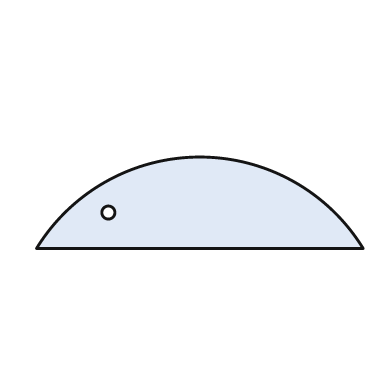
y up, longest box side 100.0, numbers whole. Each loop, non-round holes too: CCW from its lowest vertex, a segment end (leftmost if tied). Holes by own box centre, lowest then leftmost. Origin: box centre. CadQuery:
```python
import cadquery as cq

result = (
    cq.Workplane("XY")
    .moveTo(-50.0, -14.0)
    .lineTo(50.0, -14.0)
    .threePointArc((0.0, 14.0), (-50.0, -14.0))
    .close()
    .moveTo(-28.0, -3.0)
    .circle(2.0)
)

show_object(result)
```